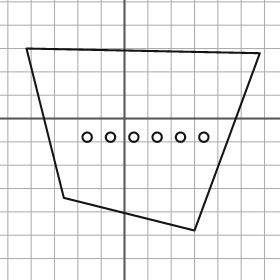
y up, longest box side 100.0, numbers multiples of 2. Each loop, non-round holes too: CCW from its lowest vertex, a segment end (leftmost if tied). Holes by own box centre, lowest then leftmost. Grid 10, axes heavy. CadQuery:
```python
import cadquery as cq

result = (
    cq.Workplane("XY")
    .moveTo(30.0, -48.0)
    .lineTo(58.0, 28.0)
    .lineTo(-42.0, 30.0)
    .lineTo(-26.0, -34.0)
    .close()
    .moveTo(-16.0, -8.0)
    .circle(2.0)
    .moveTo(-6.0, -8.0)
    .circle(2.0)
    .moveTo(4.0, -8.0)
    .circle(2.0)
    .moveTo(14.0, -8.0)
    .circle(2.0)
    .moveTo(24.0, -8.0)
    .circle(2.0)
    .moveTo(34.0, -8.0)
    .circle(2.0)
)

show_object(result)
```